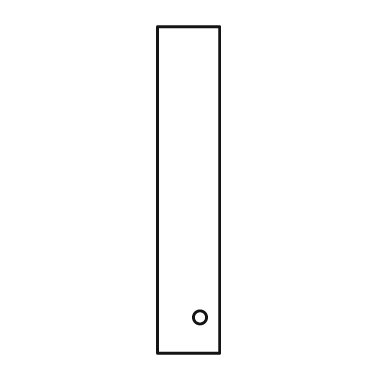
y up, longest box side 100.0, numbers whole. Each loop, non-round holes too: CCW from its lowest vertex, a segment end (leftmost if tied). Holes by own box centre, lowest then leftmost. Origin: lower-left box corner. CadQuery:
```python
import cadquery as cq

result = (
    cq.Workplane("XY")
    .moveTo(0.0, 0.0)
    .lineTo(19.0, 0.0)
    .lineTo(19.0, 100.0)
    .lineTo(0.0, 100.0)
    .close()
    .moveTo(13.0, 11.0)
    .circle(2.0)
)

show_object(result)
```